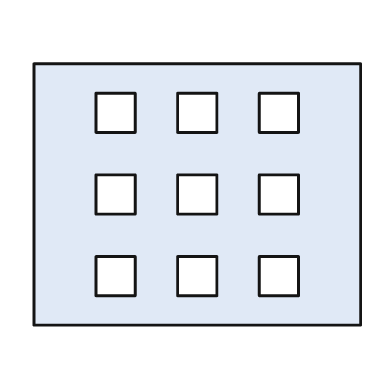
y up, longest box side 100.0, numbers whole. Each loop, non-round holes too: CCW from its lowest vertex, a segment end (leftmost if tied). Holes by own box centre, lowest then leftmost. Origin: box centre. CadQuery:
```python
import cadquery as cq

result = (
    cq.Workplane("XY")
    .moveTo(-50.0, -40.0)
    .lineTo(50.0, -40.0)
    .lineTo(50.0, 40.0)
    .lineTo(-50.0, 40.0)
    .close()
    .moveTo(-31.0, -31.0)
    .lineTo(-19.0, -31.0)
    .lineTo(-19.0, -19.0)
    .lineTo(-31.0, -19.0)
    .close()
    .moveTo(-6.0, -31.0)
    .lineTo(6.0, -31.0)
    .lineTo(6.0, -19.0)
    .lineTo(-6.0, -19.0)
    .close()
    .moveTo(19.0, -31.0)
    .lineTo(31.0, -31.0)
    .lineTo(31.0, -19.0)
    .lineTo(19.0, -19.0)
    .close()
    .moveTo(-31.0, -6.0)
    .lineTo(-19.0, -6.0)
    .lineTo(-19.0, 6.0)
    .lineTo(-31.0, 6.0)
    .close()
    .moveTo(-6.0, -6.0)
    .lineTo(6.0, -6.0)
    .lineTo(6.0, 6.0)
    .lineTo(-6.0, 6.0)
    .close()
    .moveTo(19.0, -6.0)
    .lineTo(31.0, -6.0)
    .lineTo(31.0, 6.0)
    .lineTo(19.0, 6.0)
    .close()
    .moveTo(-31.0, 19.0)
    .lineTo(-19.0, 19.0)
    .lineTo(-19.0, 31.0)
    .lineTo(-31.0, 31.0)
    .close()
    .moveTo(-6.0, 19.0)
    .lineTo(6.0, 19.0)
    .lineTo(6.0, 31.0)
    .lineTo(-6.0, 31.0)
    .close()
    .moveTo(19.0, 19.0)
    .lineTo(31.0, 19.0)
    .lineTo(31.0, 31.0)
    .lineTo(19.0, 31.0)
    .close()
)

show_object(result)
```